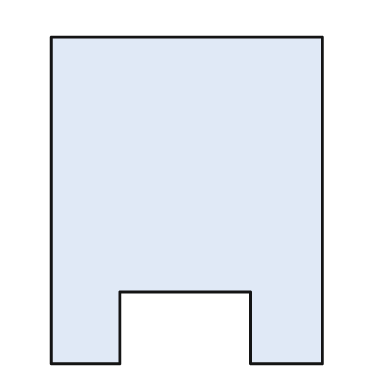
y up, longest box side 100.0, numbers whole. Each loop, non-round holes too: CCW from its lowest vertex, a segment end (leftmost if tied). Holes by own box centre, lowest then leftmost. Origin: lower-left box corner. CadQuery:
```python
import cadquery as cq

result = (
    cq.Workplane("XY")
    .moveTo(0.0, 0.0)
    .lineTo(21.0, 0.0)
    .lineTo(21.0, 22.0)
    .lineTo(61.0, 22.0)
    .lineTo(61.0, 0.0)
    .lineTo(83.0, 0.0)
    .lineTo(83.0, 100.0)
    .lineTo(0.0, 100.0)
    .close()
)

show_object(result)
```